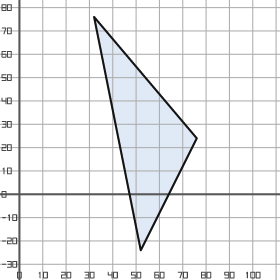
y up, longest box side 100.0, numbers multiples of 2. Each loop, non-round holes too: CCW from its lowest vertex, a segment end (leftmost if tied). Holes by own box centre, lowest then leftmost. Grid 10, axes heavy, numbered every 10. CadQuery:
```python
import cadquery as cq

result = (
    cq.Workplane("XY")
    .moveTo(52.0, -24.0)
    .lineTo(76.0, 24.0)
    .lineTo(32.0, 76.0)
    .close()
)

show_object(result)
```